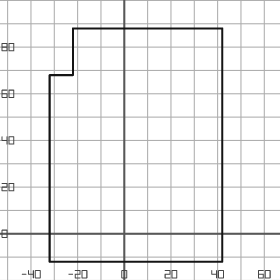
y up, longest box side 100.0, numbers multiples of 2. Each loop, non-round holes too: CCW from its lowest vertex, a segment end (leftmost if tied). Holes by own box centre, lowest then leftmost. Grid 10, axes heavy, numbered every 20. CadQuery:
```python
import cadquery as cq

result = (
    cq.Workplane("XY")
    .moveTo(-32.0, -12.0)
    .lineTo(42.0, -12.0)
    .lineTo(42.0, 88.0)
    .lineTo(-22.0, 88.0)
    .lineTo(-22.0, 68.0)
    .lineTo(-32.0, 68.0)
    .close()
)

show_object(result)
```